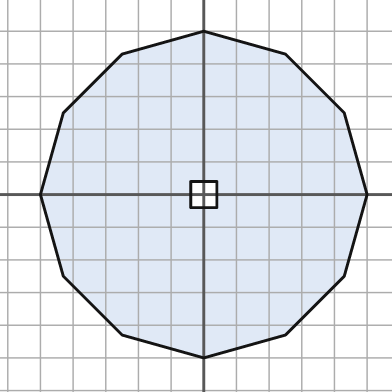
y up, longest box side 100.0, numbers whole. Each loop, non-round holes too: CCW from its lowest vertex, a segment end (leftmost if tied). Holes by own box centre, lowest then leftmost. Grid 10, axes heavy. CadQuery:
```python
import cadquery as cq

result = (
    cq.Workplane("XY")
    .moveTo(0.0, -50.0)
    .lineTo(25.0, -43.0)
    .lineTo(43.0, -25.0)
    .lineTo(50.0, 0.0)
    .lineTo(43.0, 25.0)
    .lineTo(25.0, 43.0)
    .lineTo(0.0, 50.0)
    .lineTo(-25.0, 43.0)
    .lineTo(-43.0, 25.0)
    .lineTo(-50.0, 0.0)
    .lineTo(-43.0, -25.0)
    .lineTo(-25.0, -43.0)
    .close()
    .moveTo(-4.0, -4.0)
    .lineTo(4.0, -4.0)
    .lineTo(4.0, 4.0)
    .lineTo(-4.0, 4.0)
    .close()
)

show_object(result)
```